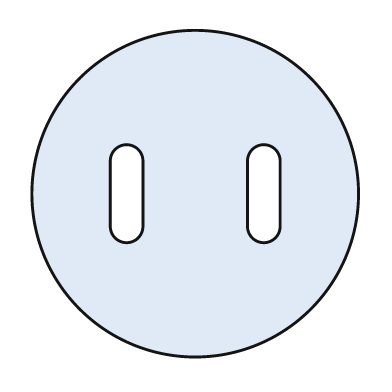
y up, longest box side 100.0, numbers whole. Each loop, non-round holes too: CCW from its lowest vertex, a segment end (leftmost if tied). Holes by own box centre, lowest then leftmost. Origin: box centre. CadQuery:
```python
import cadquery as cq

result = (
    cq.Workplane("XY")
    .moveTo(0.0, 0.0)
    .circle(50.0)
    .moveTo(-26.0, -10.0)
    .threePointArc((-21.0, -15.0), (-16.0, -10.0))
    .lineTo(-16.0, 10.0)
    .threePointArc((-21.0, 15.0), (-26.0, 10.0))
    .close()
    .moveTo(16.0, -10.0)
    .threePointArc((21.0, -15.0), (26.0, -10.0))
    .lineTo(26.0, 10.0)
    .threePointArc((21.0, 15.0), (16.0, 10.0))
    .close()
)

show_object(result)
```